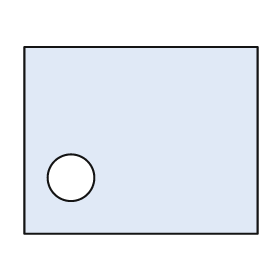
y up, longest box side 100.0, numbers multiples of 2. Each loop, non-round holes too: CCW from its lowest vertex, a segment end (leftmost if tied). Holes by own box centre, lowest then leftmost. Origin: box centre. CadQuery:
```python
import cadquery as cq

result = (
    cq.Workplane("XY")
    .moveTo(-50.0, -40.0)
    .lineTo(50.0, -40.0)
    .lineTo(50.0, 40.0)
    .lineTo(-50.0, 40.0)
    .close()
    .moveTo(-30.0, -16.0)
    .circle(10.0)
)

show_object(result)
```